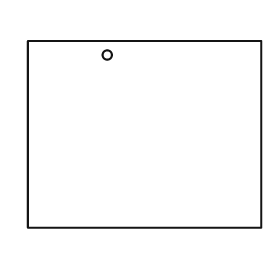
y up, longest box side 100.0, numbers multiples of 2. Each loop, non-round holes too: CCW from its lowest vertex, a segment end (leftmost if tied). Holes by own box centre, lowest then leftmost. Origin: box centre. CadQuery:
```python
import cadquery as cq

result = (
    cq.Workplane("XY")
    .moveTo(-50.0, -40.0)
    .lineTo(50.0, -40.0)
    .lineTo(50.0, 40.0)
    .lineTo(-50.0, 40.0)
    .close()
    .moveTo(-16.0, 34.0)
    .circle(2.0)
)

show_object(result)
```